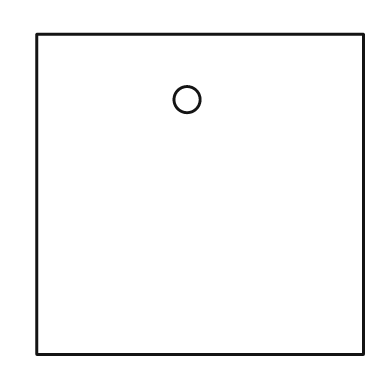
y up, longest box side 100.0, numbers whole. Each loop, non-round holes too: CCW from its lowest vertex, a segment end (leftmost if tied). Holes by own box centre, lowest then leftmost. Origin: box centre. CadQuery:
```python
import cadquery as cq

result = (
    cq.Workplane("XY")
    .moveTo(-50.0, -49.0)
    .lineTo(50.0, -49.0)
    .lineTo(50.0, 49.0)
    .lineTo(-50.0, 49.0)
    .close()
    .moveTo(-4.0, 29.0)
    .circle(4.0)
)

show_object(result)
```